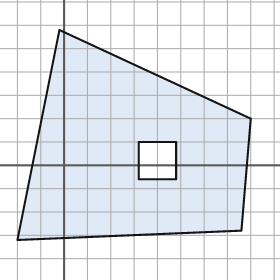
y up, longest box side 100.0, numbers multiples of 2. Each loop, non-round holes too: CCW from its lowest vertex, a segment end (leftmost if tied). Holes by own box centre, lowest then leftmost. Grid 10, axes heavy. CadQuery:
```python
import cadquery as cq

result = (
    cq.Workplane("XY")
    .moveTo(-20.0, -32.0)
    .lineTo(76.0, -28.0)
    .lineTo(80.0, 20.0)
    .lineTo(-2.0, 58.0)
    .close()
    .moveTo(32.0, -6.0)
    .lineTo(48.0, -6.0)
    .lineTo(48.0, 10.0)
    .lineTo(32.0, 10.0)
    .close()
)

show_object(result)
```